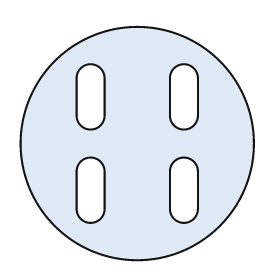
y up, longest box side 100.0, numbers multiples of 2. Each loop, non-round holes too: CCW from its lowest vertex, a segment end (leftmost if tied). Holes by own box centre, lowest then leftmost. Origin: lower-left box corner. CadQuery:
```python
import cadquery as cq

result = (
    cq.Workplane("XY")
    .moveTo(50.0, 50.0)
    .circle(50.0)
    .moveTo(24.0, 22.0)
    .threePointArc((30.0, 16.0), (36.0, 22.0))
    .lineTo(36.0, 38.0)
    .threePointArc((30.0, 44.0), (24.0, 38.0))
    .close()
    .moveTo(64.0, 22.0)
    .threePointArc((70.0, 16.0), (76.0, 22.0))
    .lineTo(76.0, 38.0)
    .threePointArc((70.0, 44.0), (64.0, 38.0))
    .close()
    .moveTo(24.0, 62.0)
    .threePointArc((30.0, 56.0), (36.0, 62.0))
    .lineTo(36.0, 78.0)
    .threePointArc((30.0, 84.0), (24.0, 78.0))
    .close()
    .moveTo(64.0, 62.0)
    .threePointArc((70.0, 56.0), (76.0, 62.0))
    .lineTo(76.0, 78.0)
    .threePointArc((70.0, 84.0), (64.0, 78.0))
    .close()
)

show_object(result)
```